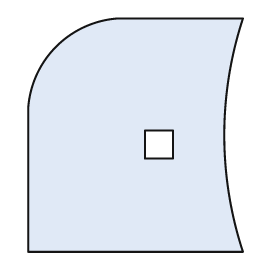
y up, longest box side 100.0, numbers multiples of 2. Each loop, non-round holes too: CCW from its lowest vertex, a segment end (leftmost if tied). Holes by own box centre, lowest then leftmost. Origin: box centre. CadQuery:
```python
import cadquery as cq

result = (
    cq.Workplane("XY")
    .moveTo(-46.0, -50.0)
    .lineTo(46.0, -50.0)
    .threePointArc((38.0, 0.0), (46.0, 50.0))
    .lineTo(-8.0, 50.0)
    .threePointArc((-34.0, 38.0), (-46.0, 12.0))
    .close()
    .moveTo(4.0, -10.0)
    .lineTo(16.0, -10.0)
    .lineTo(16.0, 2.0)
    .lineTo(4.0, 2.0)
    .close()
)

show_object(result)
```